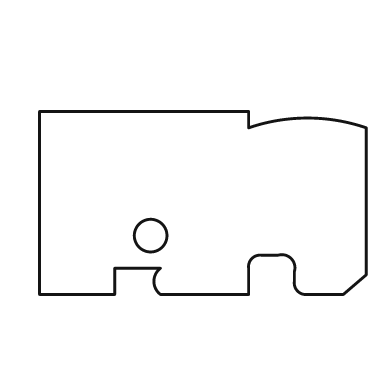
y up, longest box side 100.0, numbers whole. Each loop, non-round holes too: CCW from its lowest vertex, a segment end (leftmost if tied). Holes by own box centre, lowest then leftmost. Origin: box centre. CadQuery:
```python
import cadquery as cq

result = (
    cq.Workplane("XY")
    .moveTo(-50.0, -28.0)
    .lineTo(-27.0, -28.0)
    .lineTo(-27.0, -20.0)
    .lineTo(-13.0, -20.0)
    .threePointArc((-15.0, -24.0), (-13.0, -28.0))
    .lineTo(14.0, -28.0)
    .lineTo(14.0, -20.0)
    .threePointArc((15.0, -17.0), (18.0, -16.0))
    .lineTo(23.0, -16.0)
    .threePointArc((27.0, -17.0), (28.0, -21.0))
    .lineTo(28.0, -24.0)
    .threePointArc((29.0, -27.0), (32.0, -28.0))
    .lineTo(43.0, -28.0)
    .lineTo(50.0, -22.0)
    .lineTo(50.0, 23.0)
    .threePointArc((32.0, 26.0), (14.0, 23.0))
    .lineTo(14.0, 28.0)
    .lineTo(-50.0, 28.0)
    .close()
    .moveTo(-16.0, -10.0)
    .circle(5.0)
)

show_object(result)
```